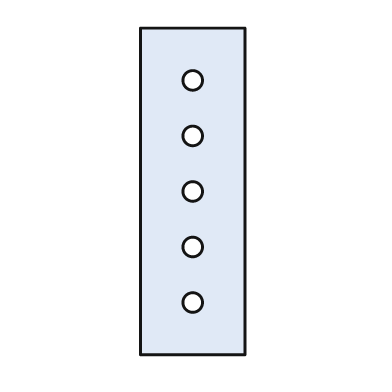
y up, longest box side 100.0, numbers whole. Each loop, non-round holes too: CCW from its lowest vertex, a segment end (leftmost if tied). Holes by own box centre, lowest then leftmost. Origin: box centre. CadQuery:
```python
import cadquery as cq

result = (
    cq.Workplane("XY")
    .moveTo(-16.0, -50.0)
    .lineTo(16.0, -50.0)
    .lineTo(16.0, 50.0)
    .lineTo(-16.0, 50.0)
    .close()
    .moveTo(0.0, -34.0)
    .circle(3.0)
    .moveTo(0.0, -17.0)
    .circle(3.0)
    .moveTo(0.0, 0.0)
    .circle(3.0)
    .moveTo(0.0, 17.0)
    .circle(3.0)
    .moveTo(0.0, 34.0)
    .circle(3.0)
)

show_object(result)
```